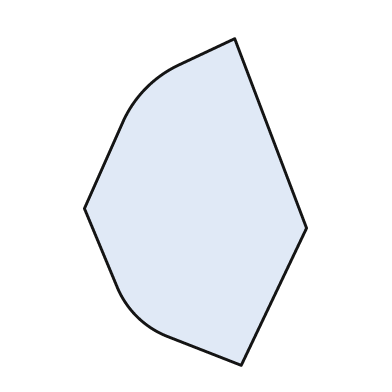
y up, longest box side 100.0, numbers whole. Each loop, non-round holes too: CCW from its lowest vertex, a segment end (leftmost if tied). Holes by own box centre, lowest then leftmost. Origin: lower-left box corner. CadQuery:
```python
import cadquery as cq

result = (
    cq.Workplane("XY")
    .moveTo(48.0, 0.0)
    .lineTo(68.0, 42.0)
    .lineTo(46.0, 100.0)
    .lineTo(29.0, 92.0)
    .threePointArc((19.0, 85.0), (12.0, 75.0))
    .lineTo(0.0, 48.0)
    .lineTo(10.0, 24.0)
    .threePointArc((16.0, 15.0), (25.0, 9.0))
    .close()
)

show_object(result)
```